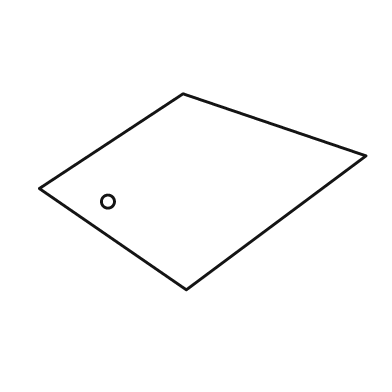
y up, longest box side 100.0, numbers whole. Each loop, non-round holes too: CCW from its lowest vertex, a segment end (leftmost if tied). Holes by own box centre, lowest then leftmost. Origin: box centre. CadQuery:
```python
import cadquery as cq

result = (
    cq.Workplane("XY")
    .moveTo(-5.0, -30.0)
    .lineTo(50.0, 11.0)
    .lineTo(-6.0, 30.0)
    .lineTo(-50.0, 1.0)
    .close()
    .moveTo(-29.0, -3.0)
    .circle(2.0)
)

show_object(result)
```